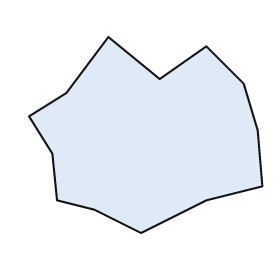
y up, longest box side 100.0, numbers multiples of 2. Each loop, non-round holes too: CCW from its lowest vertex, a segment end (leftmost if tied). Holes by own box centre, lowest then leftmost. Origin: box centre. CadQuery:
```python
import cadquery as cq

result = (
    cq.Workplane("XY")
    .moveTo(-2.0, -42.0)
    .lineTo(26.0, -28.0)
    .lineTo(50.0, -22.0)
    .lineTo(48.0, 2.0)
    .lineTo(42.0, 22.0)
    .lineTo(26.0, 38.0)
    .lineTo(6.0, 24.0)
    .lineTo(-16.0, 42.0)
    .lineTo(-34.0, 18.0)
    .lineTo(-50.0, 8.0)
    .lineTo(-40.0, -8.0)
    .lineTo(-38.0, -28.0)
    .lineTo(-22.0, -32.0)
    .close()
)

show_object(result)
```